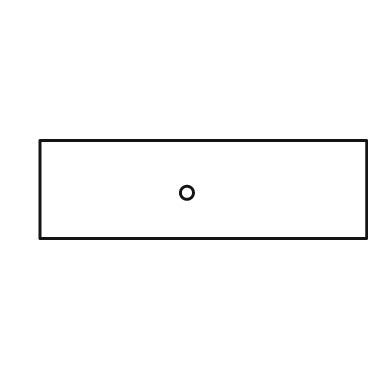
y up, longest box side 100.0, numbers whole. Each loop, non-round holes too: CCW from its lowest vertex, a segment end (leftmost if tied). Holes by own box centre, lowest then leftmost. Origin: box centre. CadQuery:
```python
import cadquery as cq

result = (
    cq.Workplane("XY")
    .moveTo(-50.0, -15.0)
    .lineTo(50.0, -15.0)
    .lineTo(50.0, 15.0)
    .lineTo(-50.0, 15.0)
    .close()
    .moveTo(-5.0, -1.0)
    .circle(2.0)
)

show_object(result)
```